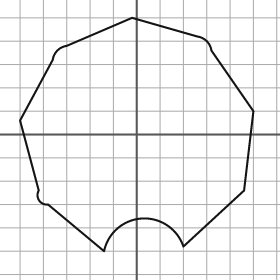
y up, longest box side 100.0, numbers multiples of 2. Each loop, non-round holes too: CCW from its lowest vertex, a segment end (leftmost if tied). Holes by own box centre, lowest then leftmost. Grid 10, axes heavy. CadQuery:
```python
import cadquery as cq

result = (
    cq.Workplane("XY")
    .moveTo(-14.0, -50.0)
    .threePointArc((2.0, -36.0), (20.0, -48.0))
    .lineTo(46.0, -24.0)
    .lineTo(50.0, 10.0)
    .lineTo(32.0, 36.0)
    .threePointArc((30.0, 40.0), (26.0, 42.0))
    .lineTo(-2.0, 50.0)
    .lineTo(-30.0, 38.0)
    .threePointArc((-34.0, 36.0), (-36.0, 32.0))
    .lineTo(-50.0, 6.0)
    .lineTo(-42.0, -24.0)
    .threePointArc((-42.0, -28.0), (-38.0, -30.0))
    .close()
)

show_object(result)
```